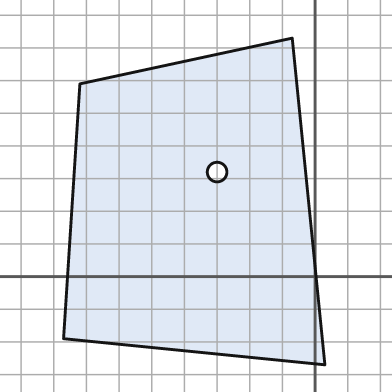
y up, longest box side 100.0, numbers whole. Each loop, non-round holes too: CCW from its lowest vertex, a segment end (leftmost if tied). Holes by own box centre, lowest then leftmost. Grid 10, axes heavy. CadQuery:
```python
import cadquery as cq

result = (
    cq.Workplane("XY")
    .moveTo(3.0, -27.0)
    .lineTo(-7.0, 73.0)
    .lineTo(-72.0, 59.0)
    .lineTo(-77.0, -19.0)
    .close()
    .moveTo(-30.0, 32.0)
    .circle(3.0)
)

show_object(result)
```